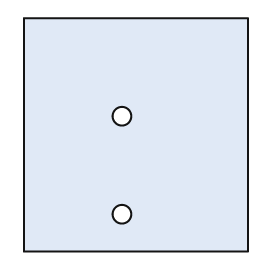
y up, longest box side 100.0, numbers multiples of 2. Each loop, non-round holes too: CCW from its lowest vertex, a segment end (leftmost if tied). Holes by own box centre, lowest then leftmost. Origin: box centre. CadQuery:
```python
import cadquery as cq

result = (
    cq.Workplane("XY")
    .moveTo(-48.0, -50.0)
    .lineTo(48.0, -50.0)
    .lineTo(48.0, 50.0)
    .lineTo(-48.0, 50.0)
    .close()
    .moveTo(-6.0, -34.0)
    .circle(4.0)
    .moveTo(-6.0, 8.0)
    .circle(4.0)
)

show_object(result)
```